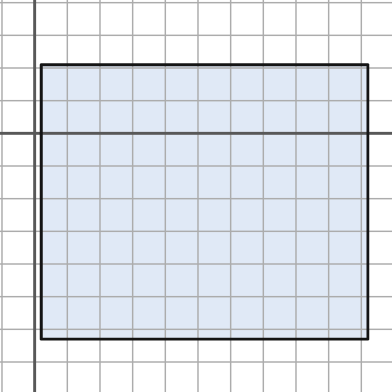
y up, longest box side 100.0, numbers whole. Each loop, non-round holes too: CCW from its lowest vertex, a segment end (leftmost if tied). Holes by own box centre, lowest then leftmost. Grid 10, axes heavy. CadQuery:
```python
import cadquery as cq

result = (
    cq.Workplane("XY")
    .moveTo(2.0, -63.0)
    .lineTo(102.0, -63.0)
    .lineTo(102.0, 21.0)
    .lineTo(2.0, 21.0)
    .close()
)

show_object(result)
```